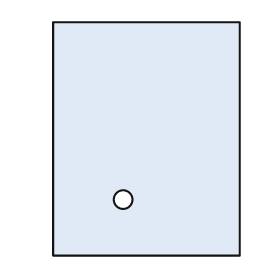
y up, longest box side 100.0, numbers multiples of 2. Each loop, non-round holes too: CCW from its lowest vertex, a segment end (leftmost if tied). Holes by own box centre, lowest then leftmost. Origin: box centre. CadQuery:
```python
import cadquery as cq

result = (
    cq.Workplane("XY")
    .moveTo(-40.0, -50.0)
    .lineTo(40.0, -50.0)
    .lineTo(40.0, 50.0)
    .lineTo(-40.0, 50.0)
    .close()
    .moveTo(-10.0, -26.0)
    .circle(4.0)
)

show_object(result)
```